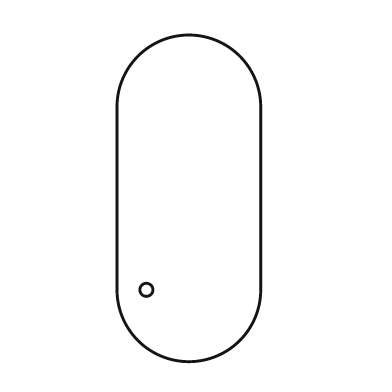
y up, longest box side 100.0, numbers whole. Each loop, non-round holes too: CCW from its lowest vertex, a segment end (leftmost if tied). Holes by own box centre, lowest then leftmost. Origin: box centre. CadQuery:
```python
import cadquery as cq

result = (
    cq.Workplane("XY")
    .moveTo(-22.0, -28.0)
    .threePointArc((0.0, -50.0), (22.0, -28.0))
    .lineTo(22.0, 28.0)
    .threePointArc((0.0, 50.0), (-22.0, 28.0))
    .close()
    .moveTo(-13.0, -28.0)
    .circle(2.0)
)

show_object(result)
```